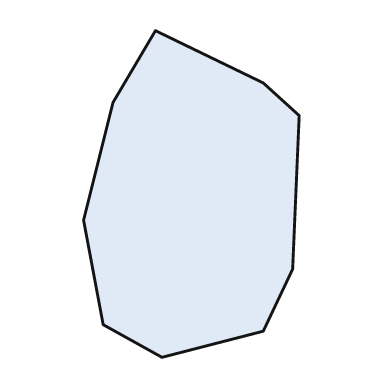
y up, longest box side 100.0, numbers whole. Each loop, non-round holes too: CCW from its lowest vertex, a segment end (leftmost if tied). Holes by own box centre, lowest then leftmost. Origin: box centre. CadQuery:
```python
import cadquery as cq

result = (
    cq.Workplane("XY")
    .moveTo(-9.0, -50.0)
    .lineTo(22.0, -42.0)
    .lineTo(31.0, -23.0)
    .lineTo(33.0, 24.0)
    .lineTo(22.0, 34.0)
    .lineTo(-11.0, 50.0)
    .lineTo(-24.0, 28.0)
    .lineTo(-33.0, -8.0)
    .lineTo(-27.0, -40.0)
    .close()
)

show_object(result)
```